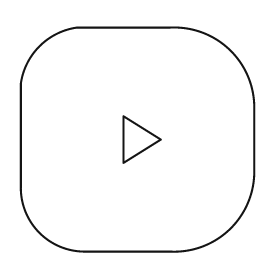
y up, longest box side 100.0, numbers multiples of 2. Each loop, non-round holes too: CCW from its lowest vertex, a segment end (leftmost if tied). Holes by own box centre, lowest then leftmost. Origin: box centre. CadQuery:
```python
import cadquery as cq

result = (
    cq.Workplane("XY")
    .moveTo(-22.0, -48.0)
    .lineTo(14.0, -48.0)
    .threePointArc((40.0, -38.0), (50.0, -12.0))
    .lineTo(50.0, 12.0)
    .threePointArc((40.0, 38.0), (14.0, 48.0))
    .lineTo(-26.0, 48.0)
    .threePointArc((-42.0, 40.0), (-50.0, 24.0))
    .lineTo(-50.0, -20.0)
    .threePointArc((-42.0, -40.0), (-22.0, -48.0))
    .close()
    .moveTo(-6.0, -10.0)
    .lineTo(10.0, 0.0)
    .lineTo(-6.0, 10.0)
    .close()
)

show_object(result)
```